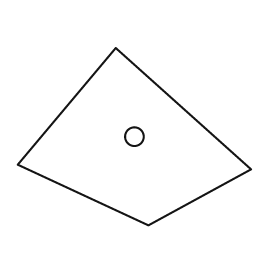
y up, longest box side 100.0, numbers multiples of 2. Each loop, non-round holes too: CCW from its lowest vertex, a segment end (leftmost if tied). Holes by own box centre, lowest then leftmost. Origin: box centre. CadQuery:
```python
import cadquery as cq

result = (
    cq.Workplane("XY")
    .moveTo(6.0, -38.0)
    .lineTo(50.0, -14.0)
    .lineTo(-8.0, 38.0)
    .lineTo(-50.0, -12.0)
    .close()
    .moveTo(0.0, 0.0)
    .circle(4.0)
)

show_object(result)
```